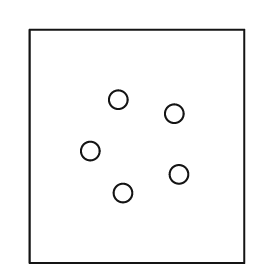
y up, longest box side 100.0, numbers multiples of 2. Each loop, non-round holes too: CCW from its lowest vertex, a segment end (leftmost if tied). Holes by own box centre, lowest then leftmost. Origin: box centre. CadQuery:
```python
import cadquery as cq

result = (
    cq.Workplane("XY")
    .moveTo(-46.0, -50.0)
    .lineTo(46.0, -50.0)
    .lineTo(46.0, 50.0)
    .lineTo(-46.0, 50.0)
    .close()
    .moveTo(-6.0, -20.0)
    .circle(4.0)
    .moveTo(18.0, -12.0)
    .circle(4.0)
    .moveTo(-20.0, -2.0)
    .circle(4.0)
    .moveTo(16.0, 14.0)
    .circle(4.0)
    .moveTo(-8.0, 20.0)
    .circle(4.0)
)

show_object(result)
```